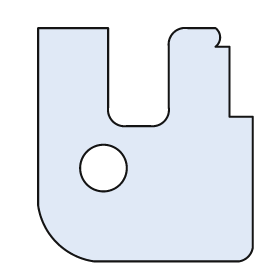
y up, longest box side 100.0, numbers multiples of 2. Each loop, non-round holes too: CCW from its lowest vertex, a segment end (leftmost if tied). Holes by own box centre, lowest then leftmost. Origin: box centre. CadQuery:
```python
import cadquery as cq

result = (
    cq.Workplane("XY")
    .moveTo(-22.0, -50.0)
    .lineTo(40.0, -50.0)
    .threePointArc((44.0, -48.0), (46.0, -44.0))
    .lineTo(46.0, 12.0)
    .lineTo(36.0, 12.0)
    .lineTo(36.0, 42.0)
    .lineTo(30.0, 42.0)
    .threePointArc((32.0, 46.0), (30.0, 50.0))
    .lineTo(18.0, 50.0)
    .threePointArc((12.0, 48.0), (10.0, 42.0))
    .lineTo(10.0, 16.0)
    .threePointArc((8.0, 10.0), (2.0, 8.0))
    .lineTo(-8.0, 8.0)
    .threePointArc((-14.0, 10.0), (-16.0, 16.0))
    .lineTo(-16.0, 50.0)
    .lineTo(-46.0, 50.0)
    .lineTo(-46.0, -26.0)
    .threePointArc((-38.0, -42.0), (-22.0, -50.0))
    .close()
    .moveTo(-18.0, -10.0)
    .circle(10.0)
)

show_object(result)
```